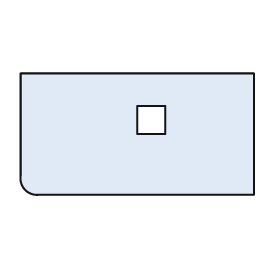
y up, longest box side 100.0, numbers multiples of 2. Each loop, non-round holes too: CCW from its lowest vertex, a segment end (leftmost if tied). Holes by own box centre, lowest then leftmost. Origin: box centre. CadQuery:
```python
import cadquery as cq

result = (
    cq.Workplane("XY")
    .moveTo(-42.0, -26.0)
    .lineTo(50.0, -26.0)
    .lineTo(50.0, 26.0)
    .lineTo(-50.0, 26.0)
    .lineTo(-50.0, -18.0)
    .threePointArc((-48.0, -24.0), (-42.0, -26.0))
    .close()
    .moveTo(0.0, 0.0)
    .lineTo(12.0, 0.0)
    .lineTo(12.0, 12.0)
    .lineTo(0.0, 12.0)
    .close()
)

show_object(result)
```